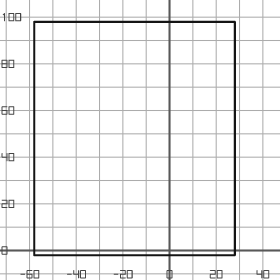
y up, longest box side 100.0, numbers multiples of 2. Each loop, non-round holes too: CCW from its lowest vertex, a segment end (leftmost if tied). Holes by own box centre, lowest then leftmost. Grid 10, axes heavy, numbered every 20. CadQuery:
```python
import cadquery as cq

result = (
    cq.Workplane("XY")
    .moveTo(-58.0, -2.0)
    .lineTo(28.0, -2.0)
    .lineTo(28.0, 98.0)
    .lineTo(-58.0, 98.0)
    .close()
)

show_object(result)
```